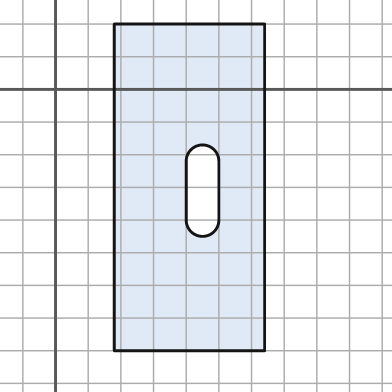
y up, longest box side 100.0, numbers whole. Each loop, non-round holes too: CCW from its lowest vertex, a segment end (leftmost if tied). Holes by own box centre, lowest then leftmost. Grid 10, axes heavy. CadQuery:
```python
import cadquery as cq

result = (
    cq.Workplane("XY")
    .moveTo(18.0, -80.0)
    .lineTo(64.0, -80.0)
    .lineTo(64.0, 20.0)
    .lineTo(18.0, 20.0)
    .close()
    .moveTo(40.0, -40.0)
    .threePointArc((45.0, -45.0), (50.0, -40.0))
    .lineTo(50.0, -22.0)
    .threePointArc((45.0, -17.0), (40.0, -22.0))
    .close()
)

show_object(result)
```